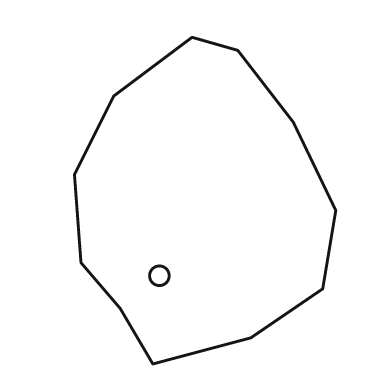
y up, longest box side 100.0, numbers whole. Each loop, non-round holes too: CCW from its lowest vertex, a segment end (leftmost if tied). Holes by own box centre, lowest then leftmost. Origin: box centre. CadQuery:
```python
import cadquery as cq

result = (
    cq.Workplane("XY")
    .moveTo(-16.0, -50.0)
    .lineTo(14.0, -42.0)
    .lineTo(36.0, -27.0)
    .lineTo(40.0, -3.0)
    .lineTo(27.0, 24.0)
    .lineTo(10.0, 46.0)
    .lineTo(-4.0, 50.0)
    .lineTo(-28.0, 32.0)
    .lineTo(-40.0, 8.0)
    .lineTo(-38.0, -19.0)
    .lineTo(-26.0, -33.0)
    .close()
    .moveTo(-14.0, -23.0)
    .circle(3.0)
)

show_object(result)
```